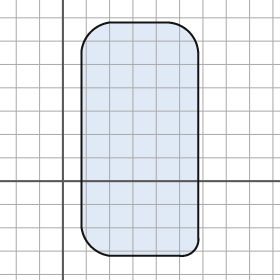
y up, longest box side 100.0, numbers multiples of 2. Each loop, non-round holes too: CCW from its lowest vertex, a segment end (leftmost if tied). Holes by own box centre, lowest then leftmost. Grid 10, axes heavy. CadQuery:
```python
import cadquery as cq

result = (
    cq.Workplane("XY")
    .moveTo(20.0, -32.0)
    .lineTo(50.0, -32.0)
    .threePointArc((56.0, -30.0), (58.0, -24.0))
    .lineTo(58.0, 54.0)
    .threePointArc((54.0, 64.0), (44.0, 68.0))
    .lineTo(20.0, 68.0)
    .threePointArc((12.0, 64.0), (8.0, 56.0))
    .lineTo(8.0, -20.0)
    .threePointArc((12.0, -28.0), (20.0, -32.0))
    .close()
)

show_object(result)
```